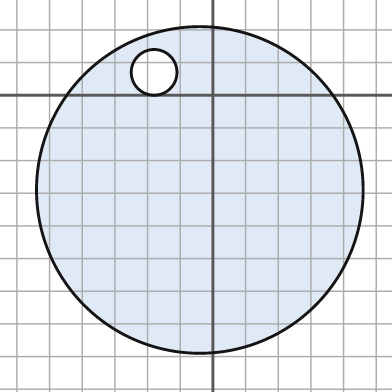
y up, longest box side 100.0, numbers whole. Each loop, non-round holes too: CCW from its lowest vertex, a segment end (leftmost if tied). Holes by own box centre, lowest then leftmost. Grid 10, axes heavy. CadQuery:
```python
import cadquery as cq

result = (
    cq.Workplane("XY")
    .moveTo(-4.0, -29.0)
    .circle(50.0)
    .moveTo(-18.0, 7.0)
    .circle(7.0)
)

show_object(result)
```